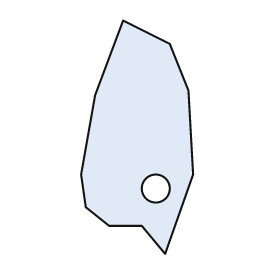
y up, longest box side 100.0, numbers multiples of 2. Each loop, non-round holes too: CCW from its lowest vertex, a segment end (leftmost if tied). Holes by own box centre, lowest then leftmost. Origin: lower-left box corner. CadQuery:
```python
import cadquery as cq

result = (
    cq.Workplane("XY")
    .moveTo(36.0, 0.0)
    .lineTo(48.0, 34.0)
    .lineTo(46.0, 70.0)
    .lineTo(38.0, 90.0)
    .lineTo(18.0, 100.0)
    .lineTo(6.0, 68.0)
    .lineTo(0.0, 34.0)
    .lineTo(2.0, 20.0)
    .lineTo(12.0, 12.0)
    .lineTo(26.0, 12.0)
    .close()
    .moveTo(32.0, 28.0)
    .circle(6.0)
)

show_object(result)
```